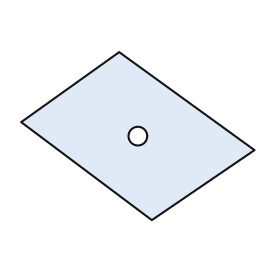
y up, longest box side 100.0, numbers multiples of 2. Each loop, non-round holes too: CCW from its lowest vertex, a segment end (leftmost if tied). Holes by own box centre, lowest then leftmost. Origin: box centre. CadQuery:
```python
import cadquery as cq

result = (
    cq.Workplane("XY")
    .moveTo(6.0, -36.0)
    .lineTo(50.0, -6.0)
    .lineTo(-8.0, 36.0)
    .lineTo(-50.0, 6.0)
    .close()
    .moveTo(0.0, 0.0)
    .circle(4.0)
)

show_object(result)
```